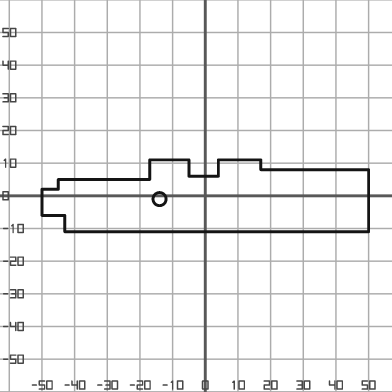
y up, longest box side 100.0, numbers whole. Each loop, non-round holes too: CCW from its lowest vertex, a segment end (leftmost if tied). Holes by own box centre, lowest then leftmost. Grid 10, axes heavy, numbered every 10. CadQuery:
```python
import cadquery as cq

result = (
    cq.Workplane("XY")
    .moveTo(-43.0, -11.0)
    .lineTo(50.0, -11.0)
    .lineTo(50.0, 8.0)
    .lineTo(17.0, 8.0)
    .lineTo(17.0, 11.0)
    .lineTo(4.0, 11.0)
    .lineTo(4.0, 6.0)
    .lineTo(-5.0, 6.0)
    .lineTo(-5.0, 11.0)
    .lineTo(-17.0, 11.0)
    .lineTo(-17.0, 5.0)
    .lineTo(-45.0, 5.0)
    .lineTo(-45.0, 2.0)
    .lineTo(-50.0, 2.0)
    .lineTo(-50.0, -6.0)
    .lineTo(-43.0, -6.0)
    .close()
    .moveTo(-14.0, -1.0)
    .circle(2.0)
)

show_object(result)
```